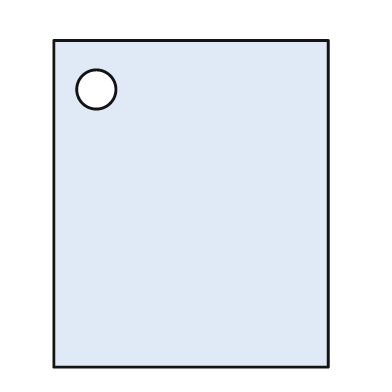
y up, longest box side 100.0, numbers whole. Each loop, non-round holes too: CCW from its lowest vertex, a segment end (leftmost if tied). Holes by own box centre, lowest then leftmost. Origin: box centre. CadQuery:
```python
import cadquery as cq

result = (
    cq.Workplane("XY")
    .moveTo(-42.0, -50.0)
    .lineTo(42.0, -50.0)
    .lineTo(42.0, 50.0)
    .lineTo(-42.0, 50.0)
    .close()
    .moveTo(-29.0, 35.0)
    .circle(6.0)
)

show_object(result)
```